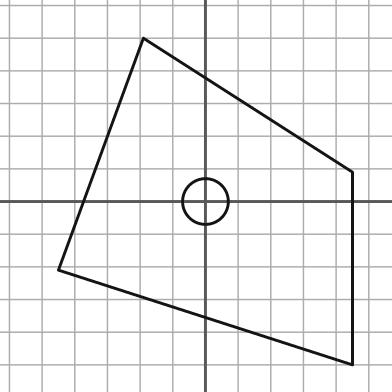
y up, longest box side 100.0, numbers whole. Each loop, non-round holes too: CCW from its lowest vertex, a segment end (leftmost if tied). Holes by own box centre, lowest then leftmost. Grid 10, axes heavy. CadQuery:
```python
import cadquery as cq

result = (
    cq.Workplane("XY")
    .moveTo(45.0, -50.0)
    .lineTo(45.0, 9.0)
    .lineTo(-19.0, 50.0)
    .lineTo(-45.0, -21.0)
    .close()
    .moveTo(0.0, 0.0)
    .circle(7.0)
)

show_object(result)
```